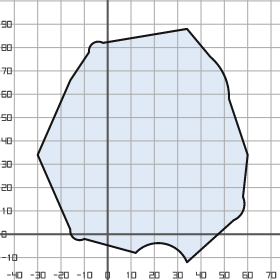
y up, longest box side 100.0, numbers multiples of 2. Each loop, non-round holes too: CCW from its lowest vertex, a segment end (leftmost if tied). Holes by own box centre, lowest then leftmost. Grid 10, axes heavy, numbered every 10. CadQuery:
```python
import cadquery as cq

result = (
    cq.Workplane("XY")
    .moveTo(34.0, -12.0)
    .lineTo(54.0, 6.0)
    .threePointArc((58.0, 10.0), (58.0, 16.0))
    .lineTo(60.0, 34.0)
    .lineTo(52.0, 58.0)
    .threePointArc((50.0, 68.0), (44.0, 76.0))
    .lineTo(34.0, 88.0)
    .lineTo(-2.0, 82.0)
    .threePointArc((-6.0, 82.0), (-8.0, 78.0))
    .lineTo(-16.0, 66.0)
    .lineTo(-30.0, 34.0)
    .lineTo(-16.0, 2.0)
    .threePointArc((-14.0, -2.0), (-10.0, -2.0))
    .lineTo(12.0, -8.0)
    .threePointArc((24.0, -4.0), (34.0, -12.0))
    .close()
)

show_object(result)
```